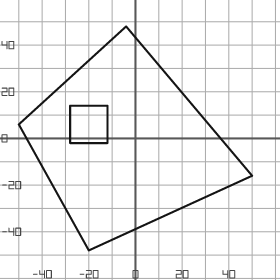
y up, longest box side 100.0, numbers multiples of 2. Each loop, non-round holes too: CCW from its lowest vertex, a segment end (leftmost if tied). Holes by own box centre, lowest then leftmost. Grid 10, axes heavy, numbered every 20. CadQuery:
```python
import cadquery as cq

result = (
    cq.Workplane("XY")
    .moveTo(-20.0, -48.0)
    .lineTo(50.0, -16.0)
    .lineTo(-4.0, 48.0)
    .lineTo(-50.0, 6.0)
    .close()
    .moveTo(-28.0, -2.0)
    .lineTo(-12.0, -2.0)
    .lineTo(-12.0, 14.0)
    .lineTo(-28.0, 14.0)
    .close()
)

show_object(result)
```